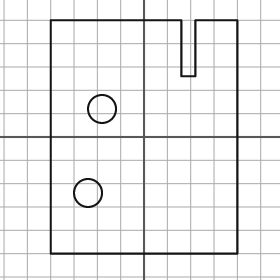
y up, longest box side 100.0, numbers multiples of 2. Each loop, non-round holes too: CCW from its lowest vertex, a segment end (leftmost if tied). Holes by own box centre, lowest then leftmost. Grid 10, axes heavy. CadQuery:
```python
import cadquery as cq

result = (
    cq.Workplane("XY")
    .moveTo(-40.0, -50.0)
    .lineTo(40.0, -50.0)
    .lineTo(40.0, 50.0)
    .lineTo(22.0, 50.0)
    .lineTo(22.0, 26.0)
    .lineTo(16.0, 26.0)
    .lineTo(16.0, 50.0)
    .lineTo(-40.0, 50.0)
    .close()
    .moveTo(-24.0, -24.0)
    .circle(6.0)
    .moveTo(-18.0, 12.0)
    .circle(6.0)
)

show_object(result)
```